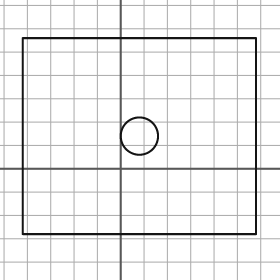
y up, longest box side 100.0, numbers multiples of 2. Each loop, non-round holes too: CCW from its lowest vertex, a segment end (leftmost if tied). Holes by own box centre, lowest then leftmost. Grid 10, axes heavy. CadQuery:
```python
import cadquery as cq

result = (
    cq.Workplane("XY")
    .moveTo(-42.0, -28.0)
    .lineTo(58.0, -28.0)
    .lineTo(58.0, 56.0)
    .lineTo(-42.0, 56.0)
    .close()
    .moveTo(8.0, 14.0)
    .circle(8.0)
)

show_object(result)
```